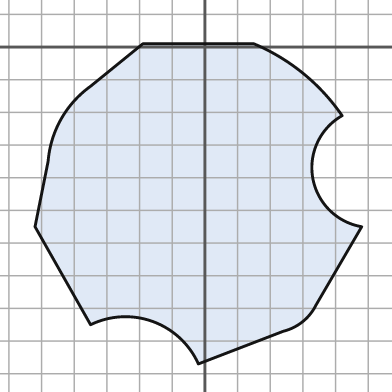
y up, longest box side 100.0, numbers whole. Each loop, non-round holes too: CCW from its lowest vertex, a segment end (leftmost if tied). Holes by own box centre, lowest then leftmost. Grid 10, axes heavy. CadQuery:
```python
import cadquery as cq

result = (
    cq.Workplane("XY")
    .moveTo(-2.0, -97.0)
    .lineTo(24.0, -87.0)
    .threePointArc((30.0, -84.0), (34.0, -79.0))
    .lineTo(48.0, -55.0)
    .threePointArc((33.0, -40.0), (42.0, -21.0))
    .threePointArc((30.0, -8.0), (15.0, 1.0))
    .lineTo(-19.0, 1.0)
    .lineTo(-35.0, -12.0)
    .threePointArc((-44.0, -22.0), (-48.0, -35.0))
    .lineTo(-52.0, -55.0)
    .lineTo(-35.0, -85.0)
    .threePointArc((-16.0, -84.0), (-2.0, -97.0))
    .close()
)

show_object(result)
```